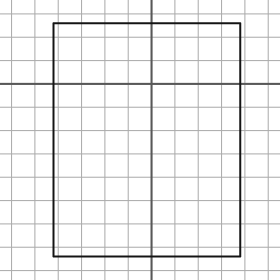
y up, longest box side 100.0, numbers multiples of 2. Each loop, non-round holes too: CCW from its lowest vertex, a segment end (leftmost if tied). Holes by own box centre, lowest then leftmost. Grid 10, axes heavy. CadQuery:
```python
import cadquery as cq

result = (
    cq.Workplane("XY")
    .moveTo(-42.0, -74.0)
    .lineTo(38.0, -74.0)
    .lineTo(38.0, 26.0)
    .lineTo(-42.0, 26.0)
    .close()
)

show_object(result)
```